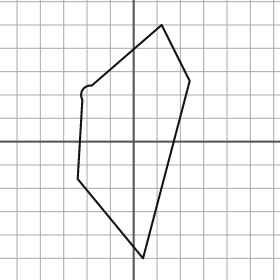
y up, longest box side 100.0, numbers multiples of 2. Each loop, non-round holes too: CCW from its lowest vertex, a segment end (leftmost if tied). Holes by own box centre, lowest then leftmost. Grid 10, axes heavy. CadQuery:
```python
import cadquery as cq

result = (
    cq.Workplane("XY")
    .moveTo(4.0, -50.0)
    .lineTo(24.0, 26.0)
    .lineTo(12.0, 50.0)
    .lineTo(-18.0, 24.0)
    .threePointArc((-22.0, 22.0), (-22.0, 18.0))
    .lineTo(-24.0, -16.0)
    .close()
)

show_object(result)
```